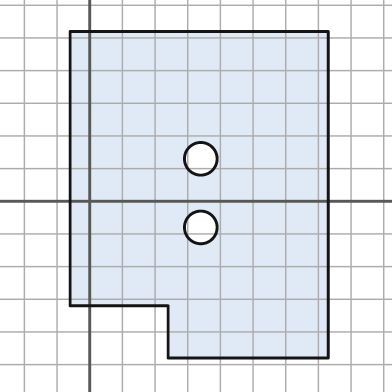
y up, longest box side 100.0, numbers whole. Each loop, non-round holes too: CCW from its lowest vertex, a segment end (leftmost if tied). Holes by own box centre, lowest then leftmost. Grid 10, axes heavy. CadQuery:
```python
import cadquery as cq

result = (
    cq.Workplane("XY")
    .moveTo(24.0, -48.0)
    .lineTo(73.0, -48.0)
    .lineTo(73.0, 52.0)
    .lineTo(-6.0, 52.0)
    .lineTo(-6.0, -32.0)
    .lineTo(24.0, -32.0)
    .close()
    .moveTo(34.0, -8.0)
    .circle(5.0)
    .moveTo(34.0, 13.0)
    .circle(5.0)
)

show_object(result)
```